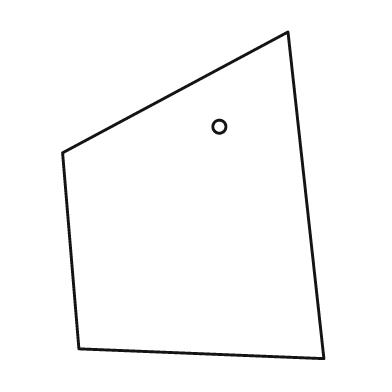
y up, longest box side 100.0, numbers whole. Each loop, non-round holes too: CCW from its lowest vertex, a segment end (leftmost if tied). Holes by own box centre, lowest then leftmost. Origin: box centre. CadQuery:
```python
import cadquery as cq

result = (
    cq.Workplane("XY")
    .moveTo(40.0, -50.0)
    .lineTo(29.0, 50.0)
    .lineTo(-40.0, 13.0)
    .lineTo(-35.0, -47.0)
    .close()
    .moveTo(8.0, 21.0)
    .circle(2.0)
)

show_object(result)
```